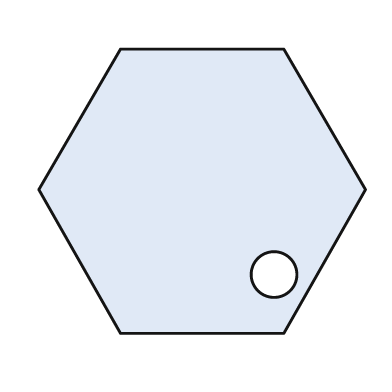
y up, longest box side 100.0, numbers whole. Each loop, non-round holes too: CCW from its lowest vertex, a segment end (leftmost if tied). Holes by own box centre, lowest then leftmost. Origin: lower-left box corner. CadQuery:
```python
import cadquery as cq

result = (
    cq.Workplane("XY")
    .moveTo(25.0, 0.0)
    .lineTo(75.0, 0.0)
    .lineTo(100.0, 44.0)
    .lineTo(75.0, 87.0)
    .lineTo(25.0, 87.0)
    .lineTo(0.0, 44.0)
    .close()
    .moveTo(72.0, 18.0)
    .circle(7.0)
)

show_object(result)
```